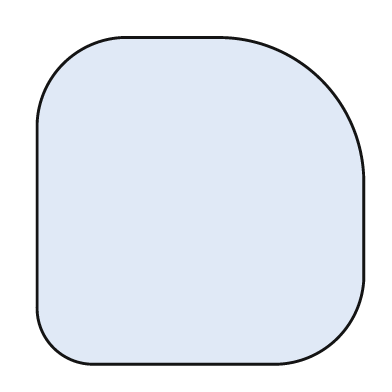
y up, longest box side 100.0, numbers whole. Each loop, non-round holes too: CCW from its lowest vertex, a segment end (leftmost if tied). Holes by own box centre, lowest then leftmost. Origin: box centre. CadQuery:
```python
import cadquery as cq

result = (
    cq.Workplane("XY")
    .moveTo(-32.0, -50.0)
    .lineTo(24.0, -50.0)
    .threePointArc((42.0, -42.0), (50.0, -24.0))
    .lineTo(50.0, 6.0)
    .threePointArc((37.0, 37.0), (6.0, 50.0))
    .lineTo(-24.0, 50.0)
    .threePointArc((-42.0, 42.0), (-50.0, 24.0))
    .lineTo(-50.0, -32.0)
    .threePointArc((-45.0, -45.0), (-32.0, -50.0))
    .close()
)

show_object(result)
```